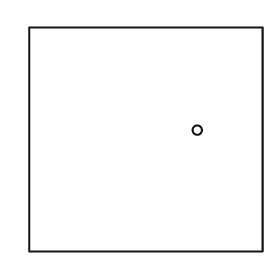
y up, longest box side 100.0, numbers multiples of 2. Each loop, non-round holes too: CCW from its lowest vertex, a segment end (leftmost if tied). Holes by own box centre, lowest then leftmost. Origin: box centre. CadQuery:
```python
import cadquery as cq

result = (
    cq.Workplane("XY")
    .moveTo(-50.0, -48.0)
    .lineTo(50.0, -48.0)
    .lineTo(50.0, 48.0)
    .lineTo(-50.0, 48.0)
    .close()
    .moveTo(22.0, 4.0)
    .circle(2.0)
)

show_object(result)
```